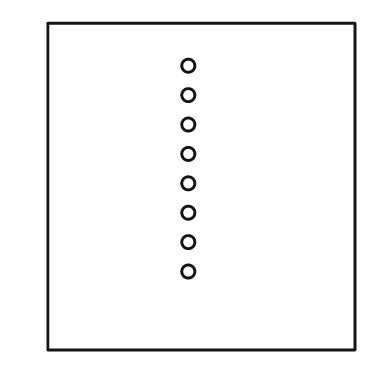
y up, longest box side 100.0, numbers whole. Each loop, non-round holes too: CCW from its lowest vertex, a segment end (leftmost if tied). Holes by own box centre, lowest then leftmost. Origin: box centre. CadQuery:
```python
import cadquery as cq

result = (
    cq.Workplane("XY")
    .moveTo(-47.0, -50.0)
    .lineTo(47.0, -50.0)
    .lineTo(47.0, 50.0)
    .lineTo(-47.0, 50.0)
    .close()
    .moveTo(-4.0, -26.0)
    .circle(2.0)
    .moveTo(-4.0, -17.0)
    .circle(2.0)
    .moveTo(-4.0, -8.0)
    .circle(2.0)
    .moveTo(-4.0, 1.0)
    .circle(2.0)
    .moveTo(-4.0, 10.0)
    .circle(2.0)
    .moveTo(-4.0, 19.0)
    .circle(2.0)
    .moveTo(-4.0, 28.0)
    .circle(2.0)
    .moveTo(-4.0, 37.0)
    .circle(2.0)
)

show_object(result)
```